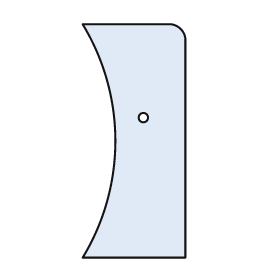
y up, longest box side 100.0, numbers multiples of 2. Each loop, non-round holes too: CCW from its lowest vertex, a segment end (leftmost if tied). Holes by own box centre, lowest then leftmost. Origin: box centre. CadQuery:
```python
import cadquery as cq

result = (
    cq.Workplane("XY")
    .moveTo(-22.0, -50.0)
    .lineTo(22.0, -50.0)
    .lineTo(22.0, 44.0)
    .threePointArc((20.0, 48.0), (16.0, 50.0))
    .lineTo(-22.0, 50.0)
    .threePointArc((-8.0, 0.0), (-22.0, -50.0))
    .close()
    .moveTo(4.0, 10.0)
    .circle(2.0)
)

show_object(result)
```